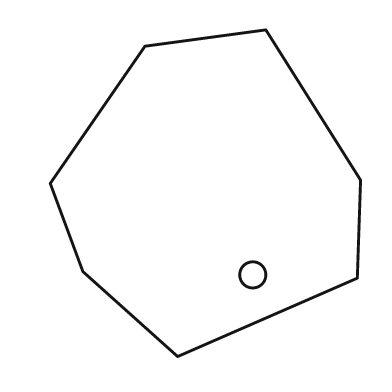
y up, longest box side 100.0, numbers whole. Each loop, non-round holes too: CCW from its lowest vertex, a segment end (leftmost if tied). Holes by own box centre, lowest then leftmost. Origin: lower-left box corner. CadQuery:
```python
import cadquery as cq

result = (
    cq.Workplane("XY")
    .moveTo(39.0, 0.0)
    .lineTo(94.0, 24.0)
    .lineTo(95.0, 54.0)
    .lineTo(66.0, 100.0)
    .lineTo(29.0, 95.0)
    .lineTo(0.0, 53.0)
    .lineTo(10.0, 26.0)
    .close()
    .moveTo(62.0, 25.0)
    .circle(4.0)
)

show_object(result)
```